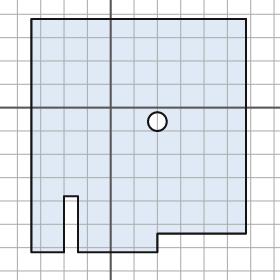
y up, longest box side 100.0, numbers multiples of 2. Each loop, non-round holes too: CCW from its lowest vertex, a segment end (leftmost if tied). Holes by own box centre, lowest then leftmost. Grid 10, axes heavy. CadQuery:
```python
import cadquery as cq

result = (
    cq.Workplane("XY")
    .moveTo(-34.0, -62.0)
    .lineTo(-20.0, -62.0)
    .lineTo(-20.0, -38.0)
    .lineTo(-14.0, -38.0)
    .lineTo(-14.0, -62.0)
    .lineTo(20.0, -62.0)
    .lineTo(20.0, -54.0)
    .lineTo(58.0, -54.0)
    .lineTo(58.0, 38.0)
    .lineTo(-34.0, 38.0)
    .close()
    .moveTo(20.0, -6.0)
    .circle(4.0)
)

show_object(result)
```